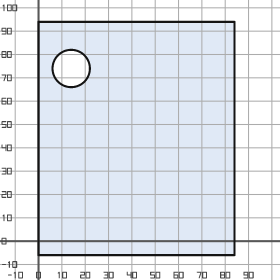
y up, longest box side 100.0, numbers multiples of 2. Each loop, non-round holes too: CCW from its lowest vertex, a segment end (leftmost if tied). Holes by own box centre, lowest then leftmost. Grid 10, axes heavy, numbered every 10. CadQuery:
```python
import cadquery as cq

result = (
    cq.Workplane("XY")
    .moveTo(0.0, -6.0)
    .lineTo(84.0, -6.0)
    .lineTo(84.0, 94.0)
    .lineTo(0.0, 94.0)
    .close()
    .moveTo(14.0, 74.0)
    .circle(8.0)
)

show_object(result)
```